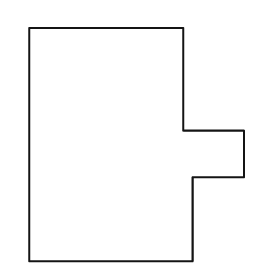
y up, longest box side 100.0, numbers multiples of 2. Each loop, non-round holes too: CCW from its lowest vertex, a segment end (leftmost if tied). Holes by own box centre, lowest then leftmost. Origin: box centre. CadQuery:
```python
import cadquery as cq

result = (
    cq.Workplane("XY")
    .moveTo(-46.0, -50.0)
    .lineTo(24.0, -50.0)
    .lineTo(24.0, -14.0)
    .lineTo(46.0, -14.0)
    .lineTo(46.0, 6.0)
    .lineTo(20.0, 6.0)
    .lineTo(20.0, 50.0)
    .lineTo(-46.0, 50.0)
    .close()
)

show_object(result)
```